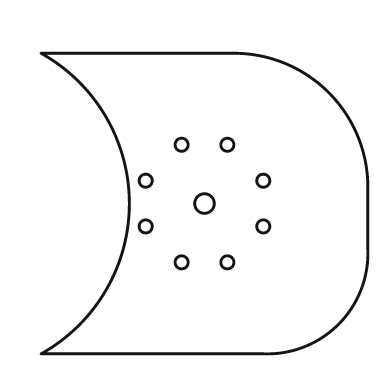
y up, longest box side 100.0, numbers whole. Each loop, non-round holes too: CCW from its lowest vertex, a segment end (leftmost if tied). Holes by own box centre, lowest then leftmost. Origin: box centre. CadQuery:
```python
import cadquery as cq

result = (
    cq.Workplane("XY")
    .moveTo(-50.0, -46.0)
    .lineTo(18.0, -46.0)
    .threePointArc((41.0, -37.0), (50.0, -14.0))
    .lineTo(50.0, 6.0)
    .threePointArc((38.0, 34.0), (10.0, 46.0))
    .lineTo(-50.0, 46.0)
    .threePointArc((-23.0, 0.0), (-50.0, -46.0))
    .close()
    .moveTo(-7.0, -18.0)
    .circle(2.0)
    .moveTo(7.0, -18.0)
    .circle(2.0)
    .moveTo(-18.0, -7.0)
    .circle(2.0)
    .moveTo(18.0, -7.0)
    .circle(2.0)
    .moveTo(0.0, 0.0)
    .circle(3.0)
    .moveTo(-18.0, 7.0)
    .circle(2.0)
    .moveTo(18.0, 7.0)
    .circle(2.0)
    .moveTo(-7.0, 18.0)
    .circle(2.0)
    .moveTo(7.0, 18.0)
    .circle(2.0)
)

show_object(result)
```